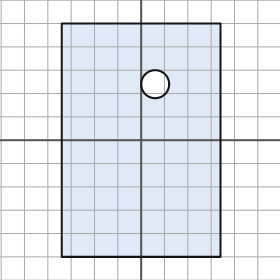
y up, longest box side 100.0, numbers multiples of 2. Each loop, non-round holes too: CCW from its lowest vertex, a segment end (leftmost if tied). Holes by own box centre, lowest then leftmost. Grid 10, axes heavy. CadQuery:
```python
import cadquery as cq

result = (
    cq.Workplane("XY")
    .moveTo(-34.0, -50.0)
    .lineTo(34.0, -50.0)
    .lineTo(34.0, 50.0)
    .lineTo(-34.0, 50.0)
    .close()
    .moveTo(6.0, 24.0)
    .circle(6.0)
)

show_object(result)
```